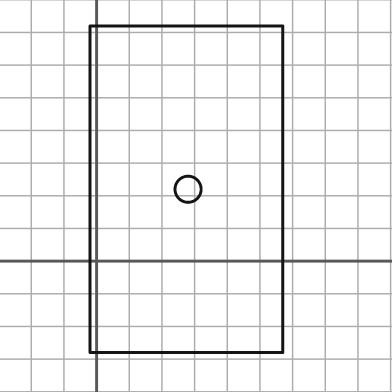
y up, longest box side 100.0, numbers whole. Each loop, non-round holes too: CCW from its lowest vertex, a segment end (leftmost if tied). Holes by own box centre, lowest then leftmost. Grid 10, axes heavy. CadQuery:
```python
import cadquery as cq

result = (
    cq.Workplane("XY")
    .moveTo(-2.0, -28.0)
    .lineTo(57.0, -28.0)
    .lineTo(57.0, 72.0)
    .lineTo(-2.0, 72.0)
    .close()
    .moveTo(28.0, 22.0)
    .circle(4.0)
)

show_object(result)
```